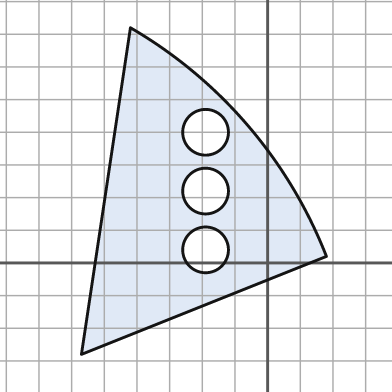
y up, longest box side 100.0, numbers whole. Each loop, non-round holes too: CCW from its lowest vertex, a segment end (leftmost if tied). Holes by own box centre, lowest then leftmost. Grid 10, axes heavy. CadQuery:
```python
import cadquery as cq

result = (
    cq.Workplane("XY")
    .moveTo(-57.0, -28.0)
    .lineTo(18.0, 2.0)
    .threePointArc((-6.0, 42.0), (-42.0, 72.0))
    .close()
    .moveTo(-19.0, 4.0)
    .circle(7.0)
    .moveTo(-19.0, 22.0)
    .circle(7.0)
    .moveTo(-19.0, 40.0)
    .circle(7.0)
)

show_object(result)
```